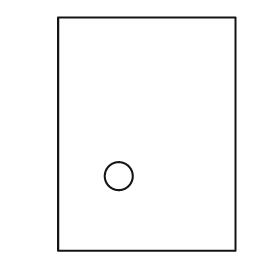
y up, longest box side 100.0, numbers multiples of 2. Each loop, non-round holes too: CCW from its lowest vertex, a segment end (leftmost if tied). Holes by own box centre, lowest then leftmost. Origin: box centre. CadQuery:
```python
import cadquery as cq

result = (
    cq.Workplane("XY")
    .moveTo(-38.0, -50.0)
    .lineTo(38.0, -50.0)
    .lineTo(38.0, 50.0)
    .lineTo(-38.0, 50.0)
    .close()
    .moveTo(-12.0, -18.0)
    .circle(6.0)
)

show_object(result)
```